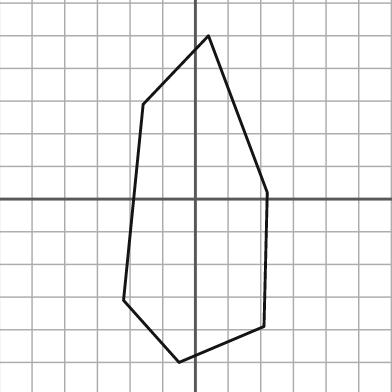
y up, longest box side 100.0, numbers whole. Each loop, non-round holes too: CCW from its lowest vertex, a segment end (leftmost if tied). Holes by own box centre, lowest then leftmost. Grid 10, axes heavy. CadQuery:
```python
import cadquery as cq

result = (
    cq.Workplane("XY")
    .moveTo(-5.0, -50.0)
    .lineTo(21.0, -39.0)
    .lineTo(22.0, 2.0)
    .lineTo(4.0, 50.0)
    .lineTo(-16.0, 29.0)
    .lineTo(-22.0, -31.0)
    .close()
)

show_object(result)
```